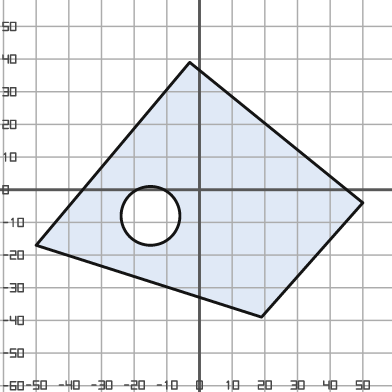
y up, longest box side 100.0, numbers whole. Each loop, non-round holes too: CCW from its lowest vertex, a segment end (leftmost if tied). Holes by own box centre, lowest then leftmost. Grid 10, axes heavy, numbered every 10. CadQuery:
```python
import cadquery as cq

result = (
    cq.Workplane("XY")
    .moveTo(19.0, -39.0)
    .lineTo(50.0, -4.0)
    .lineTo(-3.0, 39.0)
    .lineTo(-50.0, -17.0)
    .close()
    .moveTo(-15.0, -8.0)
    .circle(9.0)
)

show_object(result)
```